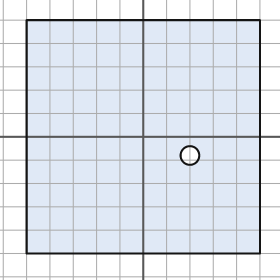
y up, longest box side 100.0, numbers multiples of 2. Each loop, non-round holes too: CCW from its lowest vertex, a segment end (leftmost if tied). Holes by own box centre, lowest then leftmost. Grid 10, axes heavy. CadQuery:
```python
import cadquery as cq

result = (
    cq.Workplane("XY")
    .moveTo(-50.0, -50.0)
    .lineTo(50.0, -50.0)
    .lineTo(50.0, 50.0)
    .lineTo(-50.0, 50.0)
    .close()
    .moveTo(20.0, -8.0)
    .circle(4.0)
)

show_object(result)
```